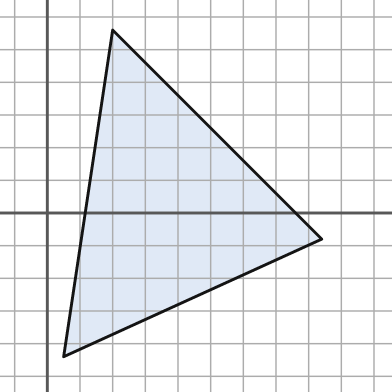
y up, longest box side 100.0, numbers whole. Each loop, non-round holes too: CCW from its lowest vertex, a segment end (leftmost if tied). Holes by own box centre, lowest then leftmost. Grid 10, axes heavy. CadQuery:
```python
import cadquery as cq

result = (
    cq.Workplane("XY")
    .moveTo(5.0, -44.0)
    .lineTo(84.0, -8.0)
    .lineTo(20.0, 56.0)
    .close()
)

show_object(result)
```